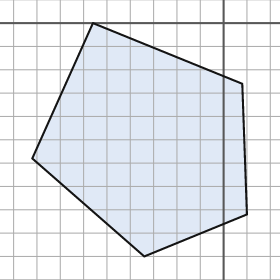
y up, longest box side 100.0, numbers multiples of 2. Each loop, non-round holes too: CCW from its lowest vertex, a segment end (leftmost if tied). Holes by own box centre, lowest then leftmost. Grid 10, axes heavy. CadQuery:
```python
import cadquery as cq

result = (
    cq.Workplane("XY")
    .moveTo(-34.0, -100.0)
    .lineTo(10.0, -82.0)
    .lineTo(8.0, -26.0)
    .lineTo(-56.0, 0.0)
    .lineTo(-82.0, -58.0)
    .close()
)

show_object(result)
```